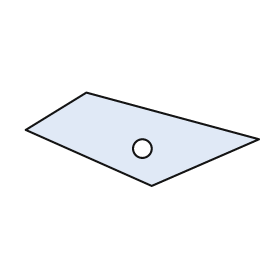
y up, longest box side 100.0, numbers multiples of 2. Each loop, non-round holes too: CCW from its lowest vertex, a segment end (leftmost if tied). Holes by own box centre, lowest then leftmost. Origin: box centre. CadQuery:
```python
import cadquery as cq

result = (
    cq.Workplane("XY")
    .moveTo(4.0, -20.0)
    .lineTo(50.0, 0.0)
    .lineTo(-24.0, 20.0)
    .lineTo(-50.0, 4.0)
    .close()
    .moveTo(0.0, -4.0)
    .circle(4.0)
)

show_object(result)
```